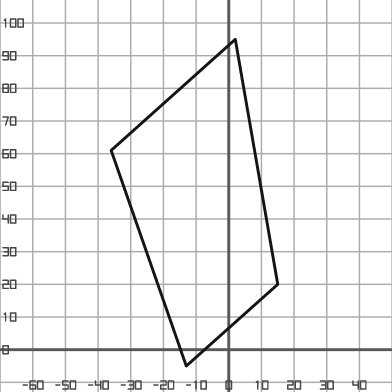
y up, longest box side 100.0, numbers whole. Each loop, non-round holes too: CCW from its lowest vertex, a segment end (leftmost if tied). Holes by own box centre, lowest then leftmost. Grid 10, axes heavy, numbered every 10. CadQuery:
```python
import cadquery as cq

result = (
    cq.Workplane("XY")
    .moveTo(-13.0, -5.0)
    .lineTo(15.0, 20.0)
    .lineTo(2.0, 95.0)
    .lineTo(-36.0, 61.0)
    .close()
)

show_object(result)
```